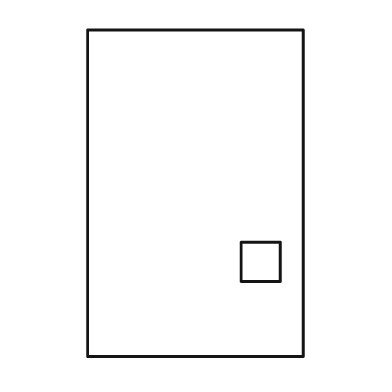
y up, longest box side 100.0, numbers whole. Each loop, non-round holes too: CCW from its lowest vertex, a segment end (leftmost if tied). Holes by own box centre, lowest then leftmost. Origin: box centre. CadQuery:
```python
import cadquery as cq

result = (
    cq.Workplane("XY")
    .moveTo(-33.0, -50.0)
    .lineTo(33.0, -50.0)
    .lineTo(33.0, 50.0)
    .lineTo(-33.0, 50.0)
    .close()
    .moveTo(14.0, -27.0)
    .lineTo(26.0, -27.0)
    .lineTo(26.0, -15.0)
    .lineTo(14.0, -15.0)
    .close()
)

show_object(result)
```